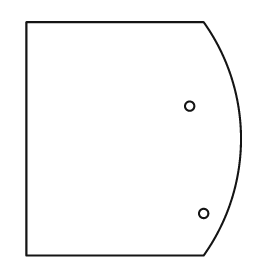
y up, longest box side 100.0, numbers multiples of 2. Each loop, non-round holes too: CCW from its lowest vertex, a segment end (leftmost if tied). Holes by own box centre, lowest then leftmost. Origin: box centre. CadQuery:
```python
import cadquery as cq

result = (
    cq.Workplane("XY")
    .moveTo(-46.0, -50.0)
    .lineTo(30.0, -50.0)
    .threePointArc((46.0, 0.0), (30.0, 50.0))
    .lineTo(-46.0, 50.0)
    .close()
    .moveTo(30.0, -32.0)
    .circle(2.0)
    .moveTo(24.0, 14.0)
    .circle(2.0)
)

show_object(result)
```